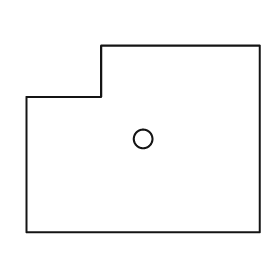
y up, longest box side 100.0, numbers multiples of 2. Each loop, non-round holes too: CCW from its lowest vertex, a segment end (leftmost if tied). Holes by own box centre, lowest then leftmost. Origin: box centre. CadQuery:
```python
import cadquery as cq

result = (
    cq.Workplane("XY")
    .moveTo(-50.0, -40.0)
    .lineTo(50.0, -40.0)
    .lineTo(50.0, 40.0)
    .lineTo(-18.0, 40.0)
    .lineTo(-18.0, 18.0)
    .lineTo(-50.0, 18.0)
    .close()
    .moveTo(0.0, 0.0)
    .circle(4.0)
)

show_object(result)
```